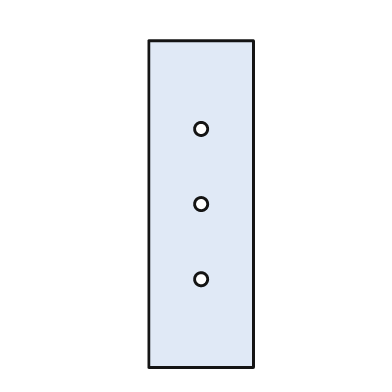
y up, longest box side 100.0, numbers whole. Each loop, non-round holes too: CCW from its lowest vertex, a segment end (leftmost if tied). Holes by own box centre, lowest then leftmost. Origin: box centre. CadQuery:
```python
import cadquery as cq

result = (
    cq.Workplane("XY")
    .moveTo(-16.0, -50.0)
    .lineTo(16.0, -50.0)
    .lineTo(16.0, 50.0)
    .lineTo(-16.0, 50.0)
    .close()
    .moveTo(0.0, -23.0)
    .circle(2.0)
    .moveTo(0.0, 0.0)
    .circle(2.0)
    .moveTo(0.0, 23.0)
    .circle(2.0)
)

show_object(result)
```